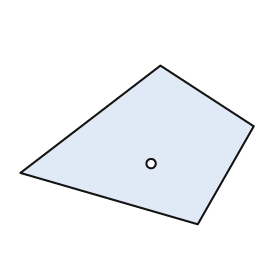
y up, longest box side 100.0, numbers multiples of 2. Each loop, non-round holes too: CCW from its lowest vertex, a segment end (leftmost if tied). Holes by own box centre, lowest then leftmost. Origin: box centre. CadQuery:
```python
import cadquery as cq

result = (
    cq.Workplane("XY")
    .moveTo(26.0, -34.0)
    .lineTo(50.0, 8.0)
    .lineTo(10.0, 34.0)
    .lineTo(-50.0, -12.0)
    .close()
    .moveTo(6.0, -8.0)
    .circle(2.0)
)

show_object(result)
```